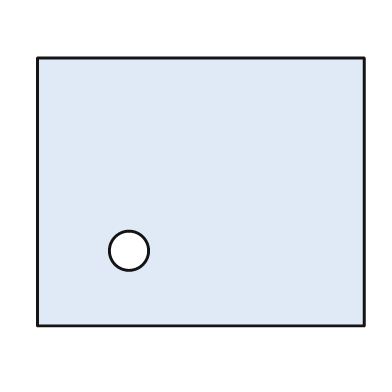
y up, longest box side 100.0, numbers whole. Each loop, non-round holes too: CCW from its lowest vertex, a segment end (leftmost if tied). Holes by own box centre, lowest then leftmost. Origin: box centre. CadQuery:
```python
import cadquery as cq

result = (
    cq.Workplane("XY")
    .moveTo(-50.0, -41.0)
    .lineTo(50.0, -41.0)
    .lineTo(50.0, 41.0)
    .lineTo(-50.0, 41.0)
    .close()
    .moveTo(-22.0, -18.0)
    .circle(6.0)
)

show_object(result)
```